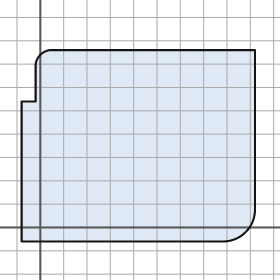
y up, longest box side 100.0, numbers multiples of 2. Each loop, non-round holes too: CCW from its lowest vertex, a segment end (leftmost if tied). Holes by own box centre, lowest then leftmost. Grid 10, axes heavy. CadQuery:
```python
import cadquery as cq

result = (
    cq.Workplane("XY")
    .moveTo(-8.0, -6.0)
    .lineTo(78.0, -6.0)
    .threePointArc((88.0, -2.0), (92.0, 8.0))
    .lineTo(92.0, 76.0)
    .lineTo(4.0, 76.0)
    .threePointArc((0.0, 74.0), (-2.0, 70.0))
    .lineTo(-2.0, 54.0)
    .lineTo(-8.0, 54.0)
    .close()
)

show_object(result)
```